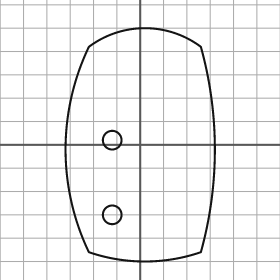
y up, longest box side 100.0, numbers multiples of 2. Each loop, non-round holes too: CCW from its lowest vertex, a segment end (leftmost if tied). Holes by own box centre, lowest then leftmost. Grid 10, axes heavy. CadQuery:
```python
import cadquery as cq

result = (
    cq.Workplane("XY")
    .moveTo(-22.0, -46.0)
    .threePointArc((2.0, -50.0), (26.0, -46.0))
    .threePointArc((32.0, -2.0), (26.0, 42.0))
    .threePointArc((2.0, 50.0), (-22.0, 42.0))
    .threePointArc((-32.0, -2.0), (-22.0, -46.0))
    .close()
    .moveTo(-12.0, -30.0)
    .circle(4.0)
    .moveTo(-12.0, 2.0)
    .circle(4.0)
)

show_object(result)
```